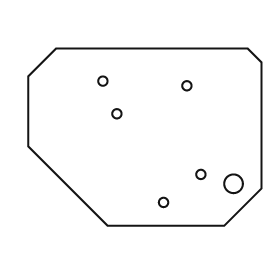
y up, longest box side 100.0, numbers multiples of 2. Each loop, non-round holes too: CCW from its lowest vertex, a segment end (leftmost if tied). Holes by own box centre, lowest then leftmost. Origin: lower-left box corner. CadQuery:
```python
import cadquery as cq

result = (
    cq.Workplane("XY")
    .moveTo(34.0, 0.0)
    .lineTo(84.0, 0.0)
    .lineTo(100.0, 16.0)
    .lineTo(100.0, 70.0)
    .lineTo(94.0, 76.0)
    .lineTo(12.0, 76.0)
    .lineTo(0.0, 64.0)
    .lineTo(0.0, 34.0)
    .close()
    .moveTo(58.0, 10.0)
    .circle(2.0)
    .moveTo(88.0, 18.0)
    .circle(4.0)
    .moveTo(74.0, 22.0)
    .circle(2.0)
    .moveTo(38.0, 48.0)
    .circle(2.0)
    .moveTo(68.0, 60.0)
    .circle(2.0)
    .moveTo(32.0, 62.0)
    .circle(2.0)
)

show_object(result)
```